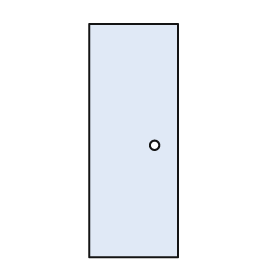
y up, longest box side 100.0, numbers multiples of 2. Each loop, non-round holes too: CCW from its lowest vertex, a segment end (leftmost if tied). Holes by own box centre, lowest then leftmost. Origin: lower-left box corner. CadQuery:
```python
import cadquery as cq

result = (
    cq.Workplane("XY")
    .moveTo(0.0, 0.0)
    .lineTo(38.0, 0.0)
    .lineTo(38.0, 100.0)
    .lineTo(0.0, 100.0)
    .close()
    .moveTo(28.0, 48.0)
    .circle(2.0)
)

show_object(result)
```